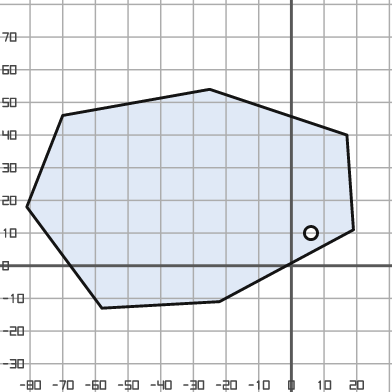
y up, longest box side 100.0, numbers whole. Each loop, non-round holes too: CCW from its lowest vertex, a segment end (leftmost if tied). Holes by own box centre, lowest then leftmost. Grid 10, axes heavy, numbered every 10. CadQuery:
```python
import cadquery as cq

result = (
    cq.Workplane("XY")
    .moveTo(-58.0, -13.0)
    .lineTo(-22.0, -11.0)
    .lineTo(19.0, 11.0)
    .lineTo(17.0, 40.0)
    .lineTo(-25.0, 54.0)
    .lineTo(-70.0, 46.0)
    .lineTo(-81.0, 18.0)
    .close()
    .moveTo(6.0, 10.0)
    .circle(2.0)
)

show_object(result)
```